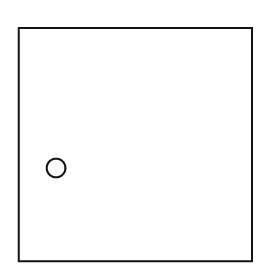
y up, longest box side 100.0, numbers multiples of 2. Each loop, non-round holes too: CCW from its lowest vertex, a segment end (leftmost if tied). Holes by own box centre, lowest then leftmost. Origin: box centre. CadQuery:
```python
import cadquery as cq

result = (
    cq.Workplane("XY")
    .moveTo(-50.0, -50.0)
    .lineTo(50.0, -50.0)
    .lineTo(50.0, 50.0)
    .lineTo(-50.0, 50.0)
    .close()
    .moveTo(-34.0, -10.0)
    .circle(4.0)
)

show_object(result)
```